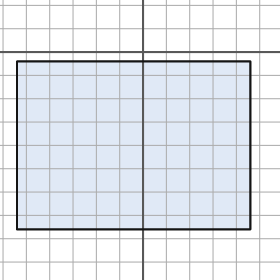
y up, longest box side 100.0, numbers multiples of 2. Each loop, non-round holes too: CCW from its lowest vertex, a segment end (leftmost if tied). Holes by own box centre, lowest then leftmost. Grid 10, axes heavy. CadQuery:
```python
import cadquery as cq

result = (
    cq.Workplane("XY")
    .moveTo(-54.0, -76.0)
    .lineTo(46.0, -76.0)
    .lineTo(46.0, -4.0)
    .lineTo(-54.0, -4.0)
    .close()
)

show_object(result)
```